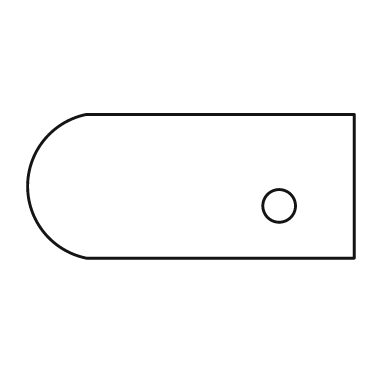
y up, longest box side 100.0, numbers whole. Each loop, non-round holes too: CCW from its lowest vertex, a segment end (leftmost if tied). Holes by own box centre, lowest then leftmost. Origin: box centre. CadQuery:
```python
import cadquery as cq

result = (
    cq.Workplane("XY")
    .moveTo(-32.0, -22.0)
    .lineTo(50.0, -22.0)
    .lineTo(50.0, 22.0)
    .lineTo(-32.0, 22.0)
    .threePointArc((-50.0, 0.0), (-32.0, -22.0))
    .close()
    .moveTo(27.0, -6.0)
    .circle(5.0)
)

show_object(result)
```